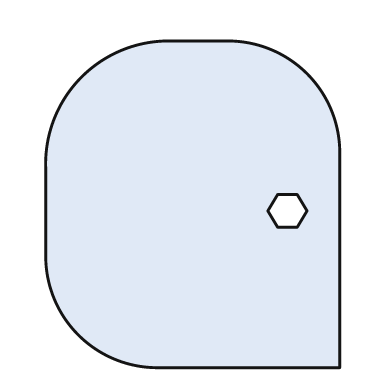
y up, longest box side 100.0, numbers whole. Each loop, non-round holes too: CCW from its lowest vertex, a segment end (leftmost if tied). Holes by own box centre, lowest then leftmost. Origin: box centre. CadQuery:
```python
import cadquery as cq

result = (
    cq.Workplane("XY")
    .moveTo(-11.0, -50.0)
    .lineTo(45.0, -50.0)
    .lineTo(45.0, 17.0)
    .threePointArc((35.0, 40.0), (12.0, 50.0))
    .lineTo(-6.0, 50.0)
    .threePointArc((-34.0, 39.0), (-45.0, 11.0))
    .lineTo(-45.0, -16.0)
    .threePointArc((-35.0, -40.0), (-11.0, -50.0))
    .close()
    .moveTo(26.0, -7.0)
    .lineTo(32.0, -7.0)
    .lineTo(35.0, -2.0)
    .lineTo(32.0, 3.0)
    .lineTo(26.0, 3.0)
    .lineTo(23.0, -2.0)
    .close()
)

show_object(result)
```